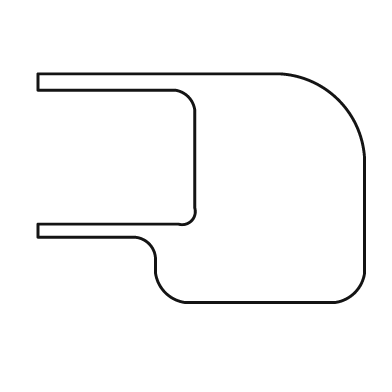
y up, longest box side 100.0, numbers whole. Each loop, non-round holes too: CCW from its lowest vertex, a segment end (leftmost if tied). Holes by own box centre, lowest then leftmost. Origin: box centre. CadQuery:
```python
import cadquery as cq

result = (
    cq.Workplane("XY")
    .moveTo(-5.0, -35.0)
    .lineTo(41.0, -35.0)
    .threePointArc((47.0, -32.0), (50.0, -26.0))
    .lineTo(50.0, 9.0)
    .threePointArc((42.0, 27.0), (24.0, 35.0))
    .lineTo(-50.0, 35.0)
    .lineTo(-50.0, 30.0)
    .lineTo(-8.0, 30.0)
    .threePointArc((-4.0, 28.0), (-2.0, 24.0))
    .lineTo(-2.0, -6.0)
    .threePointArc((-3.0, -10.0), (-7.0, -11.0))
    .lineTo(-50.0, -11.0)
    .lineTo(-50.0, -15.0)
    .lineTo(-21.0, -15.0)
    .threePointArc((-16.0, -17.0), (-14.0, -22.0))
    .lineTo(-14.0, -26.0)
    .threePointArc((-11.0, -32.0), (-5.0, -35.0))
    .close()
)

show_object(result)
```